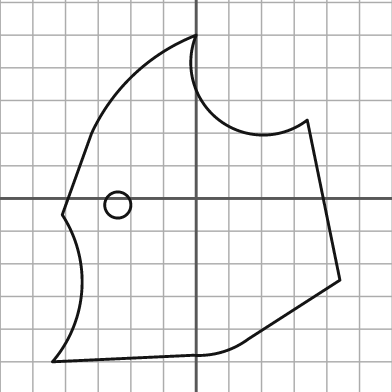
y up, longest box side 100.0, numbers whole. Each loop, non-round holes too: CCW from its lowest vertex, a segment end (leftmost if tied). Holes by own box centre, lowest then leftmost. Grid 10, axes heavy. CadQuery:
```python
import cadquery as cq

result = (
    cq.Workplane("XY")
    .moveTo(-44.0, -50.0)
    .lineTo(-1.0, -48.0)
    .threePointArc((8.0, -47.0), (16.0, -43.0))
    .lineTo(44.0, -25.0)
    .lineTo(34.0, 24.0)
    .threePointArc((7.0, 24.0), (0.0, 50.0))
    .threePointArc((-19.0, 38.0), (-32.0, 20.0))
    .lineTo(-41.0, -5.0)
    .threePointArc((-35.0, -28.0), (-44.0, -50.0))
    .close()
    .moveTo(-24.0, -2.0)
    .circle(4.0)
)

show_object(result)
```